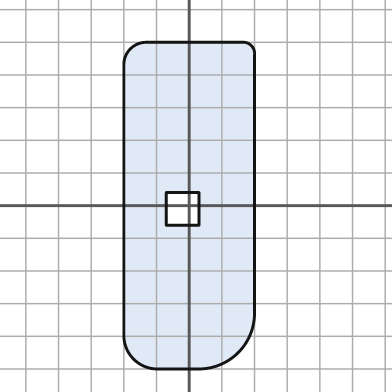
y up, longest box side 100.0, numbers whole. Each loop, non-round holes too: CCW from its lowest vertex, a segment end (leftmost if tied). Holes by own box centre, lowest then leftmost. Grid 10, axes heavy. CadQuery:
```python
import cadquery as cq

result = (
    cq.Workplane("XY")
    .moveTo(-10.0, -50.0)
    .lineTo(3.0, -50.0)
    .threePointArc((15.0, -45.0), (20.0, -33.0))
    .lineTo(20.0, 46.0)
    .threePointArc((19.0, 49.0), (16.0, 50.0))
    .lineTo(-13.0, 50.0)
    .threePointArc((-18.0, 48.0), (-20.0, 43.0))
    .lineTo(-20.0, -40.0)
    .threePointArc((-17.0, -47.0), (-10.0, -50.0))
    .close()
    .moveTo(-7.0, -6.0)
    .lineTo(3.0, -6.0)
    .lineTo(3.0, 4.0)
    .lineTo(-7.0, 4.0)
    .close()
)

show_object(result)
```